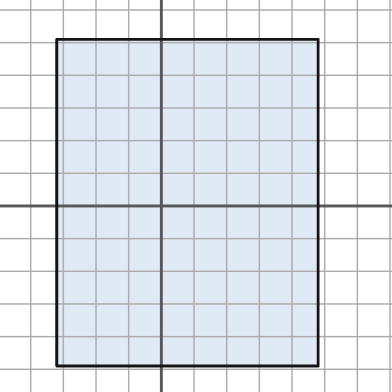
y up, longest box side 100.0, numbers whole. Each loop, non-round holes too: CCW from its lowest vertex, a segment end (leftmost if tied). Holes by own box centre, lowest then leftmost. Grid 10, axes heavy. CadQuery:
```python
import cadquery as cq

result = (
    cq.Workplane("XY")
    .moveTo(-32.0, -49.0)
    .lineTo(48.0, -49.0)
    .lineTo(48.0, 51.0)
    .lineTo(-32.0, 51.0)
    .close()
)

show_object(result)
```